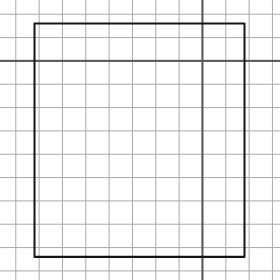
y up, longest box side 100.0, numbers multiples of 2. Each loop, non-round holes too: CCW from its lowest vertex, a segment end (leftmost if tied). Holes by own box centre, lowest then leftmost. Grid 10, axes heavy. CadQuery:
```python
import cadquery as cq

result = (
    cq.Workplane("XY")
    .moveTo(-72.0, -84.0)
    .lineTo(18.0, -84.0)
    .lineTo(18.0, 16.0)
    .lineTo(-72.0, 16.0)
    .close()
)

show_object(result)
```